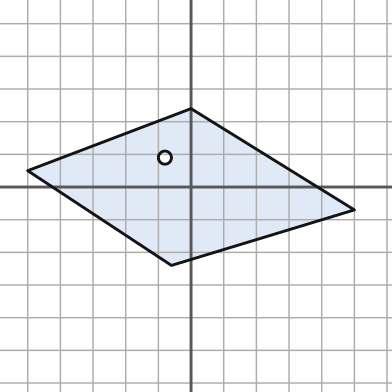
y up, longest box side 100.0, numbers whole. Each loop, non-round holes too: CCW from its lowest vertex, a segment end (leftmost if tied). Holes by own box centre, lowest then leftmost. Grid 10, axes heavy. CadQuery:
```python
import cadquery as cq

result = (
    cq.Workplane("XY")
    .moveTo(-6.0, -24.0)
    .lineTo(50.0, -7.0)
    .lineTo(0.0, 24.0)
    .lineTo(-50.0, 5.0)
    .close()
    .moveTo(-8.0, 9.0)
    .circle(2.0)
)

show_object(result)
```